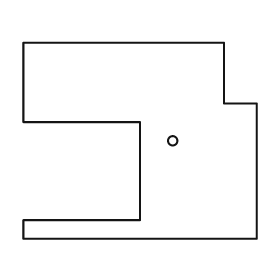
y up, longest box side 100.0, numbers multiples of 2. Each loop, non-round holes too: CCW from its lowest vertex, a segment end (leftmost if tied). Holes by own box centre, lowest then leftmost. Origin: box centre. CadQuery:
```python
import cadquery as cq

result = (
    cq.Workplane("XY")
    .moveTo(-50.0, -42.0)
    .lineTo(50.0, -42.0)
    .lineTo(50.0, 16.0)
    .lineTo(36.0, 16.0)
    .lineTo(36.0, 42.0)
    .lineTo(-50.0, 42.0)
    .lineTo(-50.0, 8.0)
    .lineTo(0.0, 8.0)
    .lineTo(0.0, -34.0)
    .lineTo(-50.0, -34.0)
    .close()
    .moveTo(14.0, 0.0)
    .circle(2.0)
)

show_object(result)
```